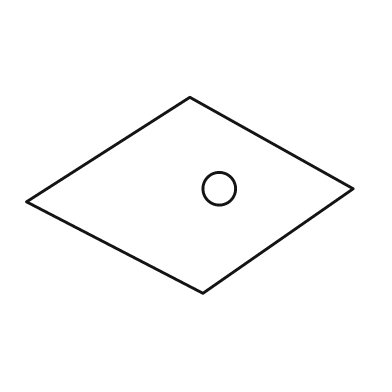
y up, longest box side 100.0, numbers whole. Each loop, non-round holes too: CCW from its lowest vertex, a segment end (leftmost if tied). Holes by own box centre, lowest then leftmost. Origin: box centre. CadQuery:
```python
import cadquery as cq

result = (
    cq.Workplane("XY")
    .moveTo(4.0, -30.0)
    .lineTo(50.0, 2.0)
    .lineTo(0.0, 30.0)
    .lineTo(-50.0, -2.0)
    .close()
    .moveTo(9.0, 2.0)
    .circle(5.0)
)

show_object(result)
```